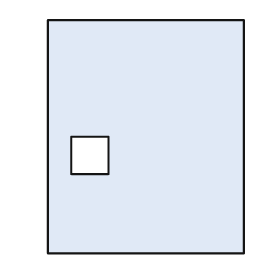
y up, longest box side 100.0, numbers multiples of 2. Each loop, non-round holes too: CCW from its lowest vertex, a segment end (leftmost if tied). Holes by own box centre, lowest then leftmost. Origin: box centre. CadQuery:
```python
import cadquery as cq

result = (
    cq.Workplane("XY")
    .moveTo(-42.0, -50.0)
    .lineTo(42.0, -50.0)
    .lineTo(42.0, 50.0)
    .lineTo(-42.0, 50.0)
    .close()
    .moveTo(-32.0, -16.0)
    .lineTo(-16.0, -16.0)
    .lineTo(-16.0, 0.0)
    .lineTo(-32.0, 0.0)
    .close()
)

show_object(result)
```